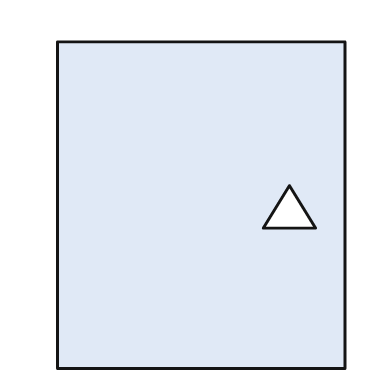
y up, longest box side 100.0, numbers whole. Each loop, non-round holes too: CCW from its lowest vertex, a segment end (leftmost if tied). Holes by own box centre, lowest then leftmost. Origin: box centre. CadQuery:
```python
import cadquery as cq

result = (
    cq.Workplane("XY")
    .moveTo(-44.0, -50.0)
    .lineTo(44.0, -50.0)
    .lineTo(44.0, 50.0)
    .lineTo(-44.0, 50.0)
    .close()
    .moveTo(19.0, -7.0)
    .lineTo(35.0, -7.0)
    .lineTo(27.0, 6.0)
    .close()
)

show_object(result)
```